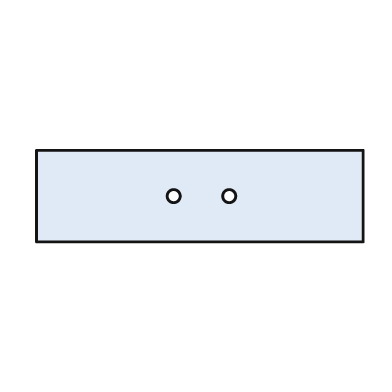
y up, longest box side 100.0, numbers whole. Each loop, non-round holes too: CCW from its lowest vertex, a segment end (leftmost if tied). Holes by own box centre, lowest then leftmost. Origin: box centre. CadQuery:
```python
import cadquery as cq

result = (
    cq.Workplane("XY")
    .moveTo(-50.0, -14.0)
    .lineTo(50.0, -14.0)
    .lineTo(50.0, 14.0)
    .lineTo(-50.0, 14.0)
    .close()
    .moveTo(-8.0, 0.0)
    .circle(2.0)
    .moveTo(9.0, 0.0)
    .circle(2.0)
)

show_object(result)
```